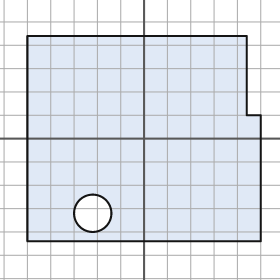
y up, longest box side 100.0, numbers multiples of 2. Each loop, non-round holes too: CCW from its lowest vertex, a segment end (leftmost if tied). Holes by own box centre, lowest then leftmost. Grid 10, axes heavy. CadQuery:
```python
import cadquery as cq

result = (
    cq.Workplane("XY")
    .moveTo(-50.0, -44.0)
    .lineTo(50.0, -44.0)
    .lineTo(50.0, 10.0)
    .lineTo(44.0, 10.0)
    .lineTo(44.0, 44.0)
    .lineTo(-50.0, 44.0)
    .close()
    .moveTo(-22.0, -32.0)
    .circle(8.0)
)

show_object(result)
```